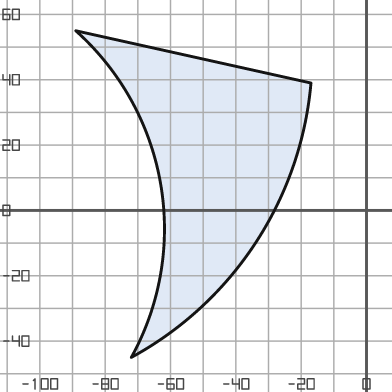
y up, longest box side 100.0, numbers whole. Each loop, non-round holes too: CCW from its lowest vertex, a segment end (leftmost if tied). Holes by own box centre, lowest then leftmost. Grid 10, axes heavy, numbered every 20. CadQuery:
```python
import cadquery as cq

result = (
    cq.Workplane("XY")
    .moveTo(-72.0, -45.0)
    .threePointArc((-34.0, -10.0), (-17.0, 39.0))
    .lineTo(-89.0, 55.0)
    .threePointArc((-63.0, 8.0), (-72.0, -45.0))
    .close()
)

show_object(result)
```